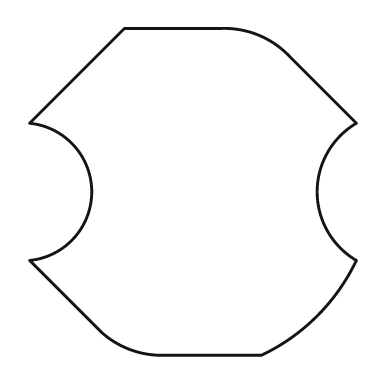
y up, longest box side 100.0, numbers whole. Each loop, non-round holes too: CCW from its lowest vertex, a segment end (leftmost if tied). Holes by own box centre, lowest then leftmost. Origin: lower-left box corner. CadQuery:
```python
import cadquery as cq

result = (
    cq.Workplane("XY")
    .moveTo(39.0, 0.0)
    .lineTo(71.0, 0.0)
    .threePointArc((88.0, 12.0), (100.0, 29.0))
    .threePointArc((88.0, 50.0), (100.0, 71.0))
    .lineTo(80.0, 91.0)
    .threePointArc((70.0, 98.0), (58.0, 100.0))
    .lineTo(29.0, 100.0)
    .lineTo(0.0, 71.0)
    .threePointArc((19.0, 50.0), (0.0, 29.0))
    .lineTo(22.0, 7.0)
    .threePointArc((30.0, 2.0), (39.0, 0.0))
    .close()
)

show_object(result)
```